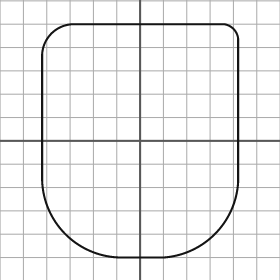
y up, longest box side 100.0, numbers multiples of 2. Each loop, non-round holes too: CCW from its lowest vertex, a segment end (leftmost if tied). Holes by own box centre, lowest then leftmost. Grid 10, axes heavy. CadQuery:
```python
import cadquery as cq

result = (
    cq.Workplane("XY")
    .moveTo(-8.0, -50.0)
    .lineTo(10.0, -50.0)
    .threePointArc((32.0, -40.0), (42.0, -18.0))
    .lineTo(42.0, 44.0)
    .threePointArc((40.0, 48.0), (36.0, 50.0))
    .lineTo(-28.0, 50.0)
    .threePointArc((-38.0, 46.0), (-42.0, 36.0))
    .lineTo(-42.0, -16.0)
    .threePointArc((-32.0, -40.0), (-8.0, -50.0))
    .close()
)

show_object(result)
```